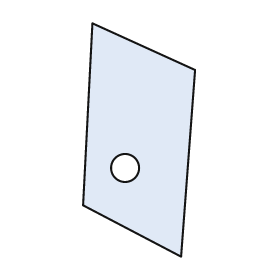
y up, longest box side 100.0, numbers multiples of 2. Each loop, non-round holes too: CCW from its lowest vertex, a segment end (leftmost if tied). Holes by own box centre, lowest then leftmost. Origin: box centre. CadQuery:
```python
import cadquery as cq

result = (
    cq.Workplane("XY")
    .moveTo(18.0, -50.0)
    .lineTo(24.0, 30.0)
    .lineTo(-20.0, 50.0)
    .lineTo(-24.0, -28.0)
    .close()
    .moveTo(-6.0, -12.0)
    .circle(6.0)
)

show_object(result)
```